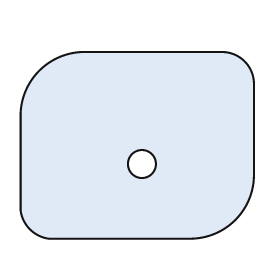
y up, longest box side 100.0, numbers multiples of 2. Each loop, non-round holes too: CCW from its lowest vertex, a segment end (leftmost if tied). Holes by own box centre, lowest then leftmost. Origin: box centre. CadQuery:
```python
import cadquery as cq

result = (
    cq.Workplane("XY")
    .moveTo(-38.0, -40.0)
    .lineTo(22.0, -40.0)
    .threePointArc((42.0, -32.0), (50.0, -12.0))
    .lineTo(50.0, 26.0)
    .threePointArc((46.0, 36.0), (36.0, 40.0))
    .lineTo(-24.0, 40.0)
    .threePointArc((-42.0, 32.0), (-50.0, 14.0))
    .lineTo(-50.0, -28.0)
    .threePointArc((-46.0, -36.0), (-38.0, -40.0))
    .close()
    .moveTo(2.0, -8.0)
    .circle(6.0)
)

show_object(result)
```